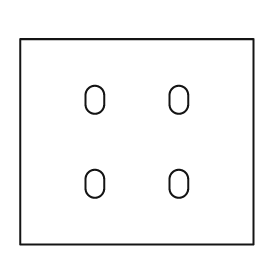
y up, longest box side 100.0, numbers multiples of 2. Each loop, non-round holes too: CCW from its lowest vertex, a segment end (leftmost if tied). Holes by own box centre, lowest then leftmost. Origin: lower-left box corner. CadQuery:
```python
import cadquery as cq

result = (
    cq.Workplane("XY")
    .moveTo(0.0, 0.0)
    .lineTo(100.0, 0.0)
    .lineTo(100.0, 88.0)
    .lineTo(0.0, 88.0)
    .close()
    .moveTo(28.0, 24.0)
    .threePointArc((32.0, 20.0), (36.0, 24.0))
    .lineTo(36.0, 28.0)
    .threePointArc((32.0, 32.0), (28.0, 28.0))
    .close()
    .moveTo(64.0, 24.0)
    .threePointArc((68.0, 20.0), (72.0, 24.0))
    .lineTo(72.0, 28.0)
    .threePointArc((68.0, 32.0), (64.0, 28.0))
    .close()
    .moveTo(28.0, 60.0)
    .threePointArc((32.0, 56.0), (36.0, 60.0))
    .lineTo(36.0, 64.0)
    .threePointArc((32.0, 68.0), (28.0, 64.0))
    .close()
    .moveTo(64.0, 60.0)
    .threePointArc((68.0, 56.0), (72.0, 60.0))
    .lineTo(72.0, 64.0)
    .threePointArc((68.0, 68.0), (64.0, 64.0))
    .close()
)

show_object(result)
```